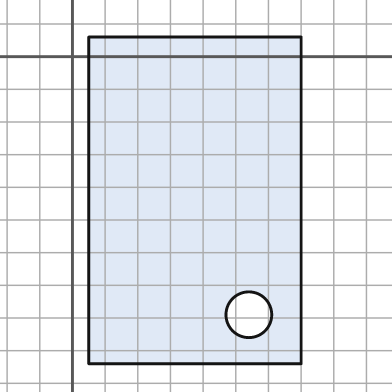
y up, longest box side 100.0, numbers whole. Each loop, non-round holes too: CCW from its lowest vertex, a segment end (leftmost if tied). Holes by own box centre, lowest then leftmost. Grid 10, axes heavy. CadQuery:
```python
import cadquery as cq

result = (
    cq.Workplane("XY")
    .moveTo(5.0, -94.0)
    .lineTo(70.0, -94.0)
    .lineTo(70.0, 6.0)
    .lineTo(5.0, 6.0)
    .close()
    .moveTo(54.0, -79.0)
    .circle(7.0)
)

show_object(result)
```